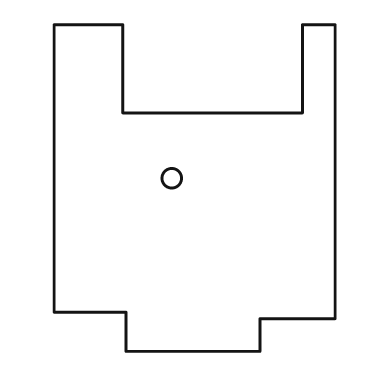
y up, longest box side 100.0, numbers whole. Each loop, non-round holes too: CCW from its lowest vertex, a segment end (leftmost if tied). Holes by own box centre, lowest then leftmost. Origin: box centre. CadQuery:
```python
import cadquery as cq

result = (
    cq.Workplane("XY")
    .moveTo(-21.0, -50.0)
    .lineTo(20.0, -50.0)
    .lineTo(20.0, -40.0)
    .lineTo(43.0, -40.0)
    .lineTo(43.0, 50.0)
    .lineTo(33.0, 50.0)
    .lineTo(33.0, 23.0)
    .lineTo(-22.0, 23.0)
    .lineTo(-22.0, 50.0)
    .lineTo(-43.0, 50.0)
    .lineTo(-43.0, -38.0)
    .lineTo(-21.0, -38.0)
    .close()
    .moveTo(-7.0, 3.0)
    .circle(3.0)
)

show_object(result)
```